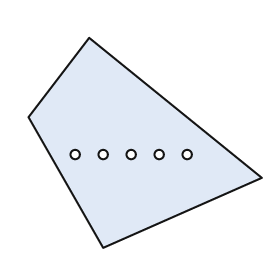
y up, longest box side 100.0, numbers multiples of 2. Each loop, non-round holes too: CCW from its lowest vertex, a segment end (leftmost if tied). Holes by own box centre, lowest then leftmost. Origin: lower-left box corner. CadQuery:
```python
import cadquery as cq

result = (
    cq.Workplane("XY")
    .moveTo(32.0, 0.0)
    .lineTo(100.0, 30.0)
    .lineTo(26.0, 90.0)
    .lineTo(0.0, 56.0)
    .close()
    .moveTo(20.0, 40.0)
    .circle(2.0)
    .moveTo(32.0, 40.0)
    .circle(2.0)
    .moveTo(44.0, 40.0)
    .circle(2.0)
    .moveTo(56.0, 40.0)
    .circle(2.0)
    .moveTo(68.0, 40.0)
    .circle(2.0)
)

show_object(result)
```